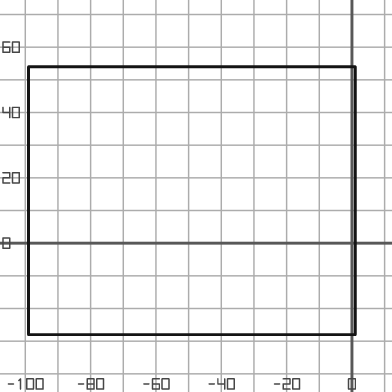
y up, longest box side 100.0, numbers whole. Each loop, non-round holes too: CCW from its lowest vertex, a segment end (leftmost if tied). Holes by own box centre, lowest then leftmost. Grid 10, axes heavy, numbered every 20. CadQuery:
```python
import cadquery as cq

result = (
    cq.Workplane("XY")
    .moveTo(-99.0, -28.0)
    .lineTo(1.0, -28.0)
    .lineTo(1.0, 54.0)
    .lineTo(-99.0, 54.0)
    .close()
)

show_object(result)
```